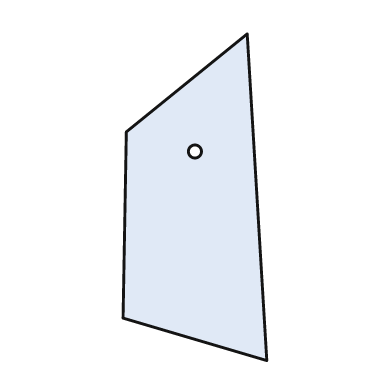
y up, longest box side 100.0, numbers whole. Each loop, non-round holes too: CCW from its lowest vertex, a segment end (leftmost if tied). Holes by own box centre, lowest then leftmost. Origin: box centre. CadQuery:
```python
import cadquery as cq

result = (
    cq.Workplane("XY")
    .moveTo(22.0, -50.0)
    .lineTo(16.0, 50.0)
    .lineTo(-21.0, 20.0)
    .lineTo(-22.0, -37.0)
    .close()
    .moveTo(0.0, 14.0)
    .circle(2.0)
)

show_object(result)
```